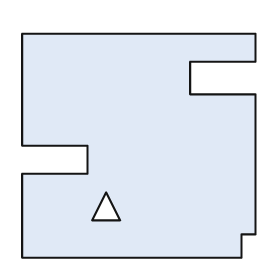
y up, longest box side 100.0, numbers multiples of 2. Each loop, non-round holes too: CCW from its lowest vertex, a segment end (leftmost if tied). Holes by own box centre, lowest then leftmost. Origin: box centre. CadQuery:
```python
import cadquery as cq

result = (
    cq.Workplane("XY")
    .moveTo(-50.0, -48.0)
    .lineTo(44.0, -48.0)
    .lineTo(44.0, -38.0)
    .lineTo(50.0, -38.0)
    .lineTo(50.0, 22.0)
    .lineTo(22.0, 22.0)
    .lineTo(22.0, 36.0)
    .lineTo(50.0, 36.0)
    .lineTo(50.0, 48.0)
    .lineTo(-50.0, 48.0)
    .lineTo(-50.0, 0.0)
    .lineTo(-22.0, 0.0)
    .lineTo(-22.0, -12.0)
    .lineTo(-50.0, -12.0)
    .close()
    .moveTo(-20.0, -32.0)
    .lineTo(-8.0, -32.0)
    .lineTo(-14.0, -20.0)
    .close()
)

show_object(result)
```